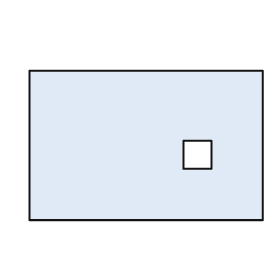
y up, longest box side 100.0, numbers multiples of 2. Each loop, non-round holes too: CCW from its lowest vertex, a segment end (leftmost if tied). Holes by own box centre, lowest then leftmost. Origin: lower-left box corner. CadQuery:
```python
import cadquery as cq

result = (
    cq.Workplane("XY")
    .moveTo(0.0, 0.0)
    .lineTo(100.0, 0.0)
    .lineTo(100.0, 64.0)
    .lineTo(0.0, 64.0)
    .close()
    .moveTo(66.0, 22.0)
    .lineTo(78.0, 22.0)
    .lineTo(78.0, 34.0)
    .lineTo(66.0, 34.0)
    .close()
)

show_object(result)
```